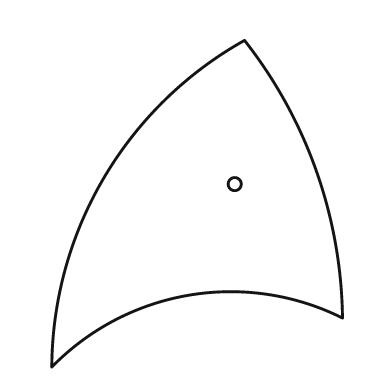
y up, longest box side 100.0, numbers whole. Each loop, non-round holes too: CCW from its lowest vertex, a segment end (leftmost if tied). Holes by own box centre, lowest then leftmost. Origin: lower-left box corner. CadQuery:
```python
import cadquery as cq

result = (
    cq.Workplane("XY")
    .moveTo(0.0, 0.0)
    .threePointArc((42.0, 22.0), (89.0, 15.0))
    .threePointArc((81.0, 60.0), (59.0, 100.0))
    .threePointArc((16.0, 58.0), (0.0, 0.0))
    .close()
    .moveTo(56.0, 56.0)
    .circle(2.0)
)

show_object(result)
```